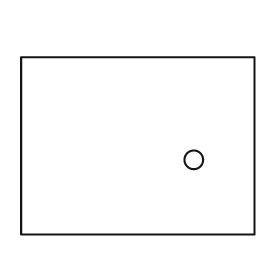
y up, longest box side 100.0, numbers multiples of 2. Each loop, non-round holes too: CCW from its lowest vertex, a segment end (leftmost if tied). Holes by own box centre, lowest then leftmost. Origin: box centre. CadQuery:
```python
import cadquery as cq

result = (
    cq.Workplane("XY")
    .moveTo(-50.0, -38.0)
    .lineTo(50.0, -38.0)
    .lineTo(50.0, 38.0)
    .lineTo(-50.0, 38.0)
    .close()
    .moveTo(24.0, -6.0)
    .circle(4.0)
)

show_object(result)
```